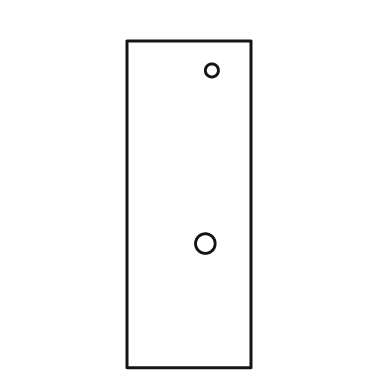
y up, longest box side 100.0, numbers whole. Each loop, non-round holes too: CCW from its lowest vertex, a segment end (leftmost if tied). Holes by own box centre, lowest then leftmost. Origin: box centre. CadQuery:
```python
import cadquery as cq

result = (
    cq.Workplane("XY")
    .moveTo(-19.0, -50.0)
    .lineTo(19.0, -50.0)
    .lineTo(19.0, 50.0)
    .lineTo(-19.0, 50.0)
    .close()
    .moveTo(5.0, -12.0)
    .circle(3.0)
    .moveTo(7.0, 41.0)
    .circle(2.0)
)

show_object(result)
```